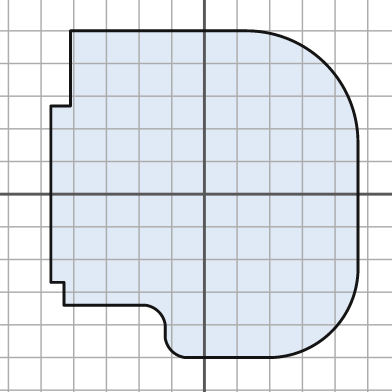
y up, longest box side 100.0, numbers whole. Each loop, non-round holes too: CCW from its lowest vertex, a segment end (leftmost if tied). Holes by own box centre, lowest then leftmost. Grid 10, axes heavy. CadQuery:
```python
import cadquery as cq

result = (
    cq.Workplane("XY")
    .moveTo(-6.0, -50.0)
    .lineTo(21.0, -50.0)
    .threePointArc((39.0, -42.0), (47.0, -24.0))
    .lineTo(47.0, 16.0)
    .threePointArc((37.0, 40.0), (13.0, 50.0))
    .lineTo(-41.0, 50.0)
    .lineTo(-41.0, 27.0)
    .lineTo(-47.0, 27.0)
    .lineTo(-47.0, -27.0)
    .lineTo(-43.0, -27.0)
    .lineTo(-43.0, -34.0)
    .lineTo(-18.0, -34.0)
    .threePointArc((-14.0, -36.0), (-12.0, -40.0))
    .lineTo(-12.0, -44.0)
    .threePointArc((-10.0, -48.0), (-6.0, -50.0))
    .close()
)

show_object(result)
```